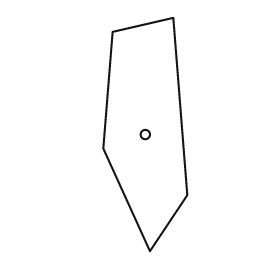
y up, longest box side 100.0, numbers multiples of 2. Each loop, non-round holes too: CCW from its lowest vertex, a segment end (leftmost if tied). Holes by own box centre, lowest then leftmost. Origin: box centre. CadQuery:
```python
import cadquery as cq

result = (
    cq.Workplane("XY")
    .moveTo(2.0, -50.0)
    .lineTo(18.0, -26.0)
    .lineTo(12.0, 50.0)
    .lineTo(-14.0, 44.0)
    .lineTo(-18.0, -6.0)
    .close()
    .moveTo(0.0, 0.0)
    .circle(2.0)
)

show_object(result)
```